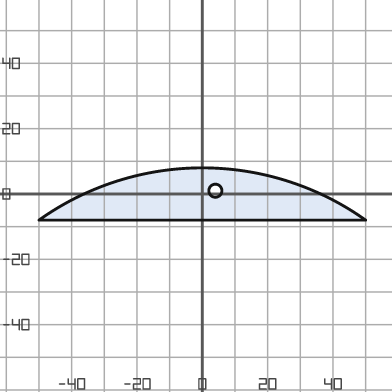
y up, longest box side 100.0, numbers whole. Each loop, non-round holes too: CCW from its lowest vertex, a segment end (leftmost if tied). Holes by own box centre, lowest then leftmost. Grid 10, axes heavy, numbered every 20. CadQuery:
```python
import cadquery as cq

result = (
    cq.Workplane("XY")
    .moveTo(-50.0, -8.0)
    .lineTo(50.0, -8.0)
    .threePointArc((0.0, 8.0), (-50.0, -8.0))
    .close()
    .moveTo(4.0, 1.0)
    .circle(2.0)
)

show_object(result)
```